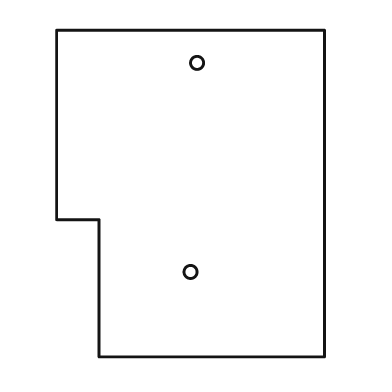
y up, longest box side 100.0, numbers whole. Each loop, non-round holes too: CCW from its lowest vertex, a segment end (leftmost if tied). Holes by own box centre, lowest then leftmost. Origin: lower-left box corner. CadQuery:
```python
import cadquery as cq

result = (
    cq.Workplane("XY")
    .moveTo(13.0, 0.0)
    .lineTo(82.0, 0.0)
    .lineTo(82.0, 100.0)
    .lineTo(0.0, 100.0)
    .lineTo(0.0, 42.0)
    .lineTo(13.0, 42.0)
    .close()
    .moveTo(41.0, 26.0)
    .circle(2.0)
    .moveTo(43.0, 90.0)
    .circle(2.0)
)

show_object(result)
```